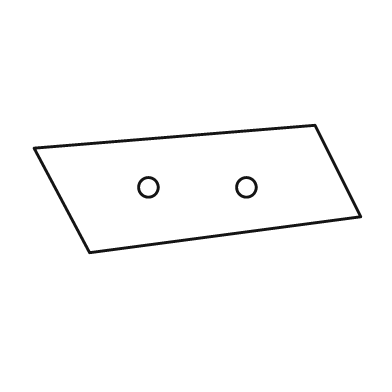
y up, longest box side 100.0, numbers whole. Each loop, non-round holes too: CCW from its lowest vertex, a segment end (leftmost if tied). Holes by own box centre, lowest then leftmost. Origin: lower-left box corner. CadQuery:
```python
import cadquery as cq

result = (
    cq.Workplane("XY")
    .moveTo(17.0, 0.0)
    .lineTo(100.0, 11.0)
    .lineTo(86.0, 39.0)
    .lineTo(0.0, 32.0)
    .close()
    .moveTo(35.0, 20.0)
    .circle(3.0)
    .moveTo(65.0, 20.0)
    .circle(3.0)
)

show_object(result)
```